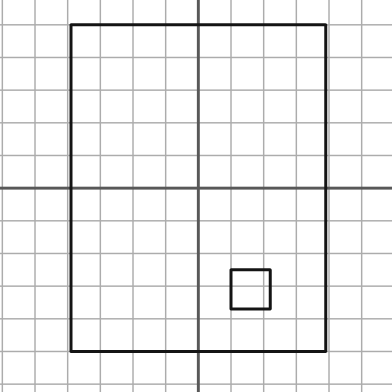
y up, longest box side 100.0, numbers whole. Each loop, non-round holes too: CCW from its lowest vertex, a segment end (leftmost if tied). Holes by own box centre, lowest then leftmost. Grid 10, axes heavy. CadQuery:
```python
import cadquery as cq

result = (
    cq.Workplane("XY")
    .moveTo(-39.0, -50.0)
    .lineTo(39.0, -50.0)
    .lineTo(39.0, 50.0)
    .lineTo(-39.0, 50.0)
    .close()
    .moveTo(10.0, -37.0)
    .lineTo(22.0, -37.0)
    .lineTo(22.0, -25.0)
    .lineTo(10.0, -25.0)
    .close()
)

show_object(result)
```